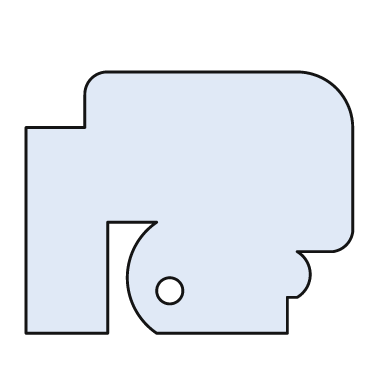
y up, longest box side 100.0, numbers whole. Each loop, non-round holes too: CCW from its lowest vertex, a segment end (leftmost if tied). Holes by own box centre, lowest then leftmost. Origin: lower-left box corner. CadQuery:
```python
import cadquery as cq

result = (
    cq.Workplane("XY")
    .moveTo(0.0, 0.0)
    .lineTo(25.0, 0.0)
    .lineTo(25.0, 34.0)
    .lineTo(40.0, 34.0)
    .threePointArc((31.0, 17.0), (40.0, 0.0))
    .lineTo(80.0, 0.0)
    .lineTo(80.0, 11.0)
    .lineTo(83.0, 11.0)
    .threePointArc((87.0, 18.0), (83.0, 25.0))
    .lineTo(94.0, 25.0)
    .threePointArc((98.0, 27.0), (100.0, 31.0))
    .lineTo(100.0, 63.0)
    .threePointArc((95.0, 75.0), (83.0, 80.0))
    .lineTo(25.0, 80.0)
    .threePointArc((20.0, 78.0), (18.0, 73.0))
    .lineTo(18.0, 63.0)
    .lineTo(0.0, 63.0)
    .close()
    .moveTo(44.0, 13.0)
    .circle(4.0)
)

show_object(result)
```